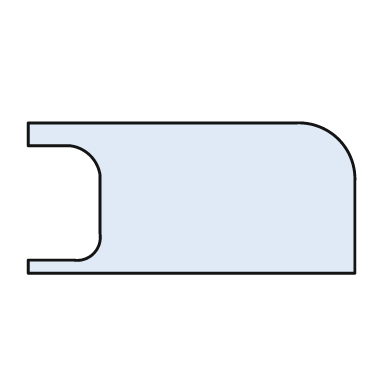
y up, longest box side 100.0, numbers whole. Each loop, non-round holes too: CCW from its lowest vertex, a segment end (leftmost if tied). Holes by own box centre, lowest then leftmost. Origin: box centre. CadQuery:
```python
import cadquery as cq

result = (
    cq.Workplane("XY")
    .moveTo(-50.0, -23.0)
    .lineTo(50.0, -23.0)
    .lineTo(50.0, 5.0)
    .threePointArc((45.0, 18.0), (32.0, 23.0))
    .lineTo(-50.0, 23.0)
    .lineTo(-50.0, 16.0)
    .lineTo(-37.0, 16.0)
    .threePointArc((-31.0, 13.0), (-28.0, 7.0))
    .lineTo(-28.0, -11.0)
    .threePointArc((-30.0, -17.0), (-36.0, -19.0))
    .lineTo(-50.0, -19.0)
    .close()
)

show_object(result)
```